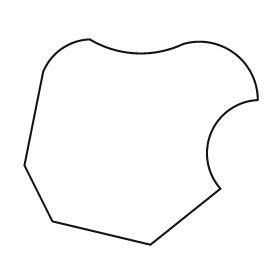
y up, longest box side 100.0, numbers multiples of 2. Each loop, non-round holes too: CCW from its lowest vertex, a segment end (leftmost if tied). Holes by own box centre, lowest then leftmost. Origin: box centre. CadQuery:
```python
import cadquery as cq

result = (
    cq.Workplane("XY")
    .moveTo(4.0, -44.0)
    .lineTo(34.0, -20.0)
    .threePointArc((30.0, 4.0), (50.0, 18.0))
    .threePointArc((40.0, 38.0), (18.0, 42.0))
    .threePointArc((-2.0, 38.0), (-22.0, 44.0))
    .threePointArc((-34.0, 40.0), (-42.0, 30.0))
    .lineTo(-50.0, -10.0)
    .lineTo(-38.0, -34.0)
    .close()
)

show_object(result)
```